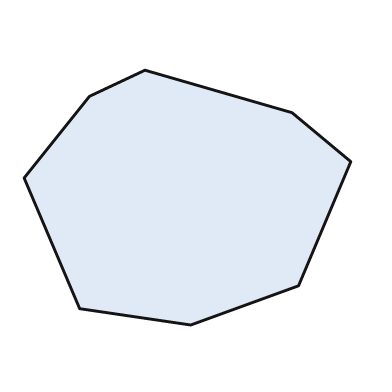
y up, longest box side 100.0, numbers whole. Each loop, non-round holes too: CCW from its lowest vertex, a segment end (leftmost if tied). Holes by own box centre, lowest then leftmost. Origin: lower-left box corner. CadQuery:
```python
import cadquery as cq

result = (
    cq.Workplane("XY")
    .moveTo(51.0, 0.0)
    .lineTo(84.0, 12.0)
    .lineTo(100.0, 50.0)
    .lineTo(82.0, 65.0)
    .lineTo(37.0, 78.0)
    .lineTo(20.0, 70.0)
    .lineTo(0.0, 45.0)
    .lineTo(17.0, 5.0)
    .close()
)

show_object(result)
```